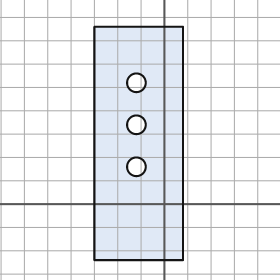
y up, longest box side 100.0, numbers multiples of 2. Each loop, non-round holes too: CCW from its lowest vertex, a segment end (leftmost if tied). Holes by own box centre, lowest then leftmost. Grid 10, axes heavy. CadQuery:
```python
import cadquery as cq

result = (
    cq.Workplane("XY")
    .moveTo(-30.0, -24.0)
    .lineTo(8.0, -24.0)
    .lineTo(8.0, 76.0)
    .lineTo(-30.0, 76.0)
    .close()
    .moveTo(-12.0, 16.0)
    .circle(4.0)
    .moveTo(-12.0, 34.0)
    .circle(4.0)
    .moveTo(-12.0, 52.0)
    .circle(4.0)
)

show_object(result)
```